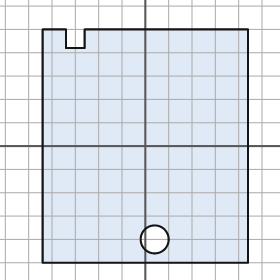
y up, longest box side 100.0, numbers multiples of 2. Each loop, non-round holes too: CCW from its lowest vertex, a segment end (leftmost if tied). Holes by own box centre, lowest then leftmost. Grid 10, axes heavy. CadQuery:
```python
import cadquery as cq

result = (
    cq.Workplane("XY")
    .moveTo(-44.0, -50.0)
    .lineTo(44.0, -50.0)
    .lineTo(44.0, 50.0)
    .lineTo(-26.0, 50.0)
    .lineTo(-26.0, 42.0)
    .lineTo(-34.0, 42.0)
    .lineTo(-34.0, 50.0)
    .lineTo(-44.0, 50.0)
    .close()
    .moveTo(4.0, -40.0)
    .circle(6.0)
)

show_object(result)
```